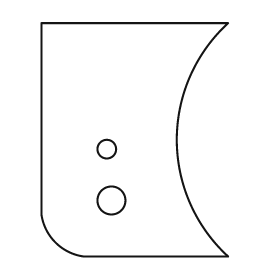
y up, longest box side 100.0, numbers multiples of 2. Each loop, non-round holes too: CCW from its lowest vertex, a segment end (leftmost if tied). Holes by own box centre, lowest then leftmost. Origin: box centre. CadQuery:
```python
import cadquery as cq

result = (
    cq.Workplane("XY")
    .moveTo(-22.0, -50.0)
    .lineTo(40.0, -50.0)
    .threePointArc((18.0, 0.0), (40.0, 50.0))
    .lineTo(-40.0, 50.0)
    .lineTo(-40.0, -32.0)
    .threePointArc((-34.0, -44.0), (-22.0, -50.0))
    .close()
    .moveTo(-10.0, -26.0)
    .circle(6.0)
    .moveTo(-12.0, -4.0)
    .circle(4.0)
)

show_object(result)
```